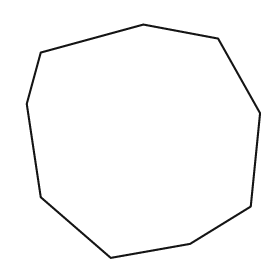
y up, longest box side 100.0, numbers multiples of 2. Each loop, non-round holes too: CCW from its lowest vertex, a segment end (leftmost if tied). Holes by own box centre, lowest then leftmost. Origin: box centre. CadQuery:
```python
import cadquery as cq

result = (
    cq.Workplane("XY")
    .moveTo(-14.0, -50.0)
    .lineTo(20.0, -44.0)
    .lineTo(46.0, -28.0)
    .lineTo(50.0, 12.0)
    .lineTo(32.0, 44.0)
    .lineTo(0.0, 50.0)
    .lineTo(-44.0, 38.0)
    .lineTo(-50.0, 16.0)
    .lineTo(-44.0, -24.0)
    .close()
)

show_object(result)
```